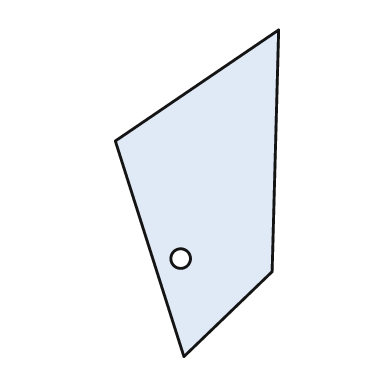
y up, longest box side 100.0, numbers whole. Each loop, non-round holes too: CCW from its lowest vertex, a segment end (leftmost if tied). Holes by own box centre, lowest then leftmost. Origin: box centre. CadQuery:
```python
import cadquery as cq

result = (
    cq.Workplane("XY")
    .moveTo(-4.0, -50.0)
    .lineTo(23.0, -24.0)
    .lineTo(25.0, 50.0)
    .lineTo(-25.0, 16.0)
    .close()
    .moveTo(-5.0, -20.0)
    .circle(3.0)
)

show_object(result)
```